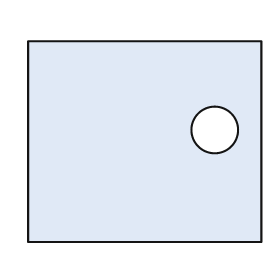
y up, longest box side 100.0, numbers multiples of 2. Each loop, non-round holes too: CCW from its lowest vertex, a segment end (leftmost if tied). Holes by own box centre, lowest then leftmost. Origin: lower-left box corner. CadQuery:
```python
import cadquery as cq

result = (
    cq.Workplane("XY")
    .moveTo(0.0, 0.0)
    .lineTo(100.0, 0.0)
    .lineTo(100.0, 86.0)
    .lineTo(0.0, 86.0)
    .close()
    .moveTo(80.0, 48.0)
    .circle(10.0)
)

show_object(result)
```